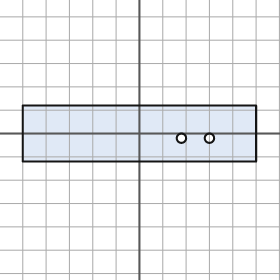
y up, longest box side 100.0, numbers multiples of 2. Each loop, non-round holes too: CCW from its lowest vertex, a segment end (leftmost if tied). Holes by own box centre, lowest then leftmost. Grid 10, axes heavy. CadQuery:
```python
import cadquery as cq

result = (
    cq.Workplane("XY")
    .moveTo(-50.0, -12.0)
    .lineTo(50.0, -12.0)
    .lineTo(50.0, 12.0)
    .lineTo(-50.0, 12.0)
    .close()
    .moveTo(18.0, -2.0)
    .circle(2.0)
    .moveTo(30.0, -2.0)
    .circle(2.0)
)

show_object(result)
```